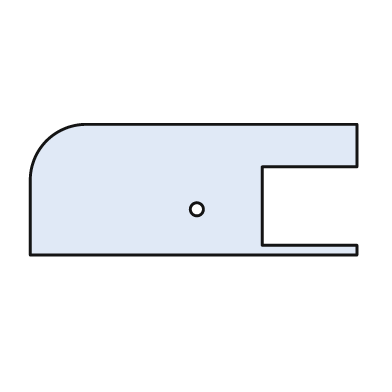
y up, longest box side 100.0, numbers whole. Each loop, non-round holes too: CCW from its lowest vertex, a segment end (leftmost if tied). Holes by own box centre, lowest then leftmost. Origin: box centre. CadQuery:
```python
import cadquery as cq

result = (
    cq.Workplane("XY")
    .moveTo(-50.0, -20.0)
    .lineTo(50.0, -20.0)
    .lineTo(50.0, -17.0)
    .lineTo(21.0, -17.0)
    .lineTo(21.0, 7.0)
    .lineTo(50.0, 7.0)
    .lineTo(50.0, 20.0)
    .lineTo(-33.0, 20.0)
    .threePointArc((-45.0, 15.0), (-50.0, 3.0))
    .close()
    .moveTo(1.0, -6.0)
    .circle(2.0)
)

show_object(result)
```